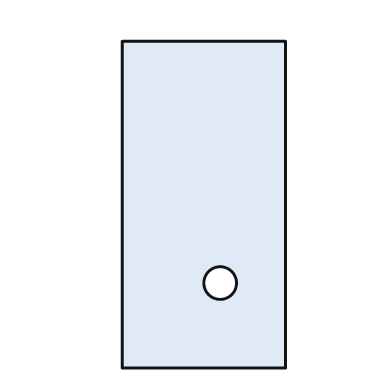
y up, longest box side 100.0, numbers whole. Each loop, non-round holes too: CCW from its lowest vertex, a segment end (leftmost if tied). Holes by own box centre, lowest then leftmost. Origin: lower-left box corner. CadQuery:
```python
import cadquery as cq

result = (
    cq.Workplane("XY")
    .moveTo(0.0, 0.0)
    .lineTo(50.0, 0.0)
    .lineTo(50.0, 100.0)
    .lineTo(0.0, 100.0)
    .close()
    .moveTo(30.0, 26.0)
    .circle(5.0)
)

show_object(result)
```